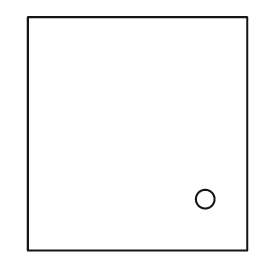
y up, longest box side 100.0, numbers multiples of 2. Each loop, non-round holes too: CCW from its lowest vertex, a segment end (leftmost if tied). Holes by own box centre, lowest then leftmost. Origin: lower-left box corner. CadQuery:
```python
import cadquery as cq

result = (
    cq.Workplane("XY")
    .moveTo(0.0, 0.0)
    .lineTo(94.0, 0.0)
    .lineTo(94.0, 100.0)
    .lineTo(0.0, 100.0)
    .close()
    .moveTo(76.0, 22.0)
    .circle(4.0)
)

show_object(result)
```